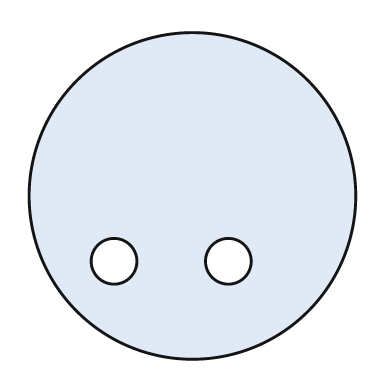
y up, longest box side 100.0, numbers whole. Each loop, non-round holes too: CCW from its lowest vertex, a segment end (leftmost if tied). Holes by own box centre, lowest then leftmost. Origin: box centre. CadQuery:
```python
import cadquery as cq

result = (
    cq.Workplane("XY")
    .moveTo(0.0, 0.0)
    .circle(50.0)
    .moveTo(-24.0, -20.0)
    .circle(7.0)
    .moveTo(11.0, -20.0)
    .circle(7.0)
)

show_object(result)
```